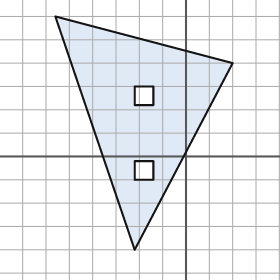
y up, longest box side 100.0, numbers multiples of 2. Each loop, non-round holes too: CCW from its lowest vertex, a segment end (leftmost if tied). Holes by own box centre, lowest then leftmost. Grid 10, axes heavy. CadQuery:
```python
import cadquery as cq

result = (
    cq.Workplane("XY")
    .moveTo(-22.0, -40.0)
    .lineTo(20.0, 40.0)
    .lineTo(-56.0, 60.0)
    .close()
    .moveTo(-22.0, -10.0)
    .lineTo(-14.0, -10.0)
    .lineTo(-14.0, -2.0)
    .lineTo(-22.0, -2.0)
    .close()
    .moveTo(-22.0, 22.0)
    .lineTo(-14.0, 22.0)
    .lineTo(-14.0, 30.0)
    .lineTo(-22.0, 30.0)
    .close()
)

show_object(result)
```